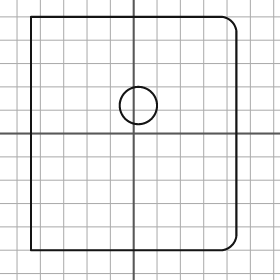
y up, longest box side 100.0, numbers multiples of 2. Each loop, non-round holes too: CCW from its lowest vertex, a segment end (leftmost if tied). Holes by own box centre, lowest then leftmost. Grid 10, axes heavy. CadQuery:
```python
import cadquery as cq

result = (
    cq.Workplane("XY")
    .moveTo(-44.0, -50.0)
    .lineTo(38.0, -50.0)
    .threePointArc((42.0, -48.0), (44.0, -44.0))
    .lineTo(44.0, 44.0)
    .threePointArc((42.0, 48.0), (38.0, 50.0))
    .lineTo(-44.0, 50.0)
    .close()
    .moveTo(2.0, 12.0)
    .circle(8.0)
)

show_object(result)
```